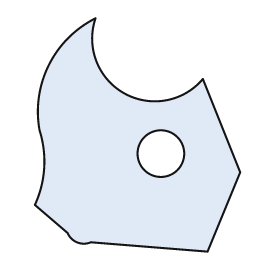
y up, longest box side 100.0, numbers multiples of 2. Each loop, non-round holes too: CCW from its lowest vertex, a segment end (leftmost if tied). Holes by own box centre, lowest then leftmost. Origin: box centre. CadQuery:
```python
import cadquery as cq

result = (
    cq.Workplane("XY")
    .moveTo(30.0, -50.0)
    .lineTo(44.0, -16.0)
    .lineTo(28.0, 24.0)
    .threePointArc((-6.0, 18.0), (-18.0, 50.0))
    .threePointArc((-38.0, 30.0), (-42.0, 2.0))
    .threePointArc((-40.0, -14.0), (-44.0, -30.0))
    .lineTo(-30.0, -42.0)
    .threePointArc((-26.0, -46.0), (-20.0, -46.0))
    .close()
    .moveTo(10.0, -8.0)
    .circle(10.0)
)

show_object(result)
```